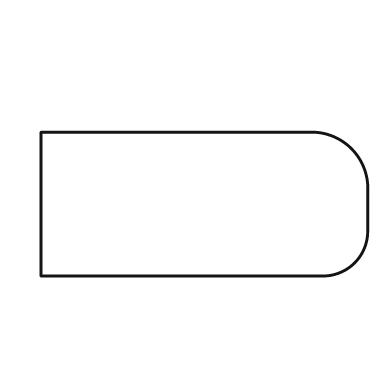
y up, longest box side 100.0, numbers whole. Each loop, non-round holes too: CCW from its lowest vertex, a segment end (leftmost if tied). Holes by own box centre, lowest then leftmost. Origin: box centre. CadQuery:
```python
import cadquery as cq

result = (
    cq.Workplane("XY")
    .moveTo(-50.0, -22.0)
    .lineTo(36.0, -22.0)
    .threePointArc((46.0, -18.0), (50.0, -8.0))
    .lineTo(50.0, 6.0)
    .threePointArc((45.0, 17.0), (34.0, 22.0))
    .lineTo(-50.0, 22.0)
    .close()
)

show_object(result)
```